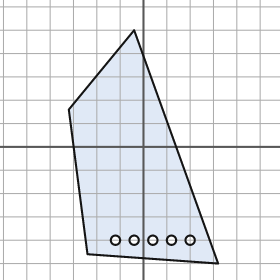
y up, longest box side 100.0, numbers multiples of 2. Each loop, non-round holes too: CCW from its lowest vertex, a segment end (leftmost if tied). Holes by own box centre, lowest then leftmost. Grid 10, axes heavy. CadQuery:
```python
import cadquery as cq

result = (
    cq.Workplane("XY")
    .moveTo(32.0, -50.0)
    .lineTo(-4.0, 50.0)
    .lineTo(-32.0, 16.0)
    .lineTo(-24.0, -46.0)
    .close()
    .moveTo(-12.0, -40.0)
    .circle(2.0)
    .moveTo(-4.0, -40.0)
    .circle(2.0)
    .moveTo(4.0, -40.0)
    .circle(2.0)
    .moveTo(12.0, -40.0)
    .circle(2.0)
    .moveTo(20.0, -40.0)
    .circle(2.0)
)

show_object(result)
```